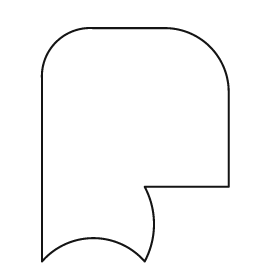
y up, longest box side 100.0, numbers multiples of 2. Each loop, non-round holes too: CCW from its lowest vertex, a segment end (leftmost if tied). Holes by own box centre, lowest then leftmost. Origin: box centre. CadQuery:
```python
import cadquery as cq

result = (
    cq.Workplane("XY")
    .moveTo(-40.0, -50.0)
    .threePointArc((-18.0, -40.0), (4.0, -50.0))
    .threePointArc((8.0, -34.0), (4.0, -18.0))
    .lineTo(40.0, -18.0)
    .lineTo(40.0, 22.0)
    .threePointArc((32.0, 42.0), (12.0, 50.0))
    .lineTo(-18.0, 50.0)
    .threePointArc((-34.0, 44.0), (-40.0, 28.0))
    .close()
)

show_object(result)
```